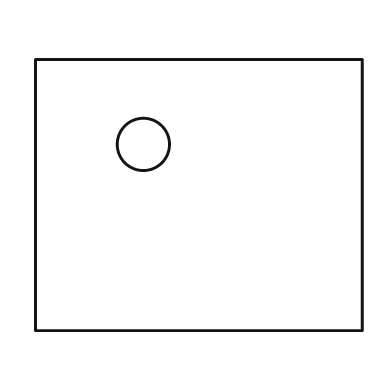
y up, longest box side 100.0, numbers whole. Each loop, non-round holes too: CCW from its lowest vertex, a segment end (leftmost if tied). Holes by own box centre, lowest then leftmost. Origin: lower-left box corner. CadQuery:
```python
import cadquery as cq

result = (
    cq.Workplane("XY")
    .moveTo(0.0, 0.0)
    .lineTo(100.0, 0.0)
    .lineTo(100.0, 83.0)
    .lineTo(0.0, 83.0)
    .close()
    .moveTo(33.0, 57.0)
    .circle(8.0)
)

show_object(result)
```